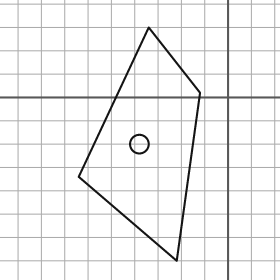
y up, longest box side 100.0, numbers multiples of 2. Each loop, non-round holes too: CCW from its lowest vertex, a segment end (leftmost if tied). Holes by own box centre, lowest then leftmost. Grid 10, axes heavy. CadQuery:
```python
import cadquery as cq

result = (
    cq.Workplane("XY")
    .moveTo(-22.0, -70.0)
    .lineTo(-12.0, 2.0)
    .lineTo(-34.0, 30.0)
    .lineTo(-64.0, -34.0)
    .close()
    .moveTo(-38.0, -20.0)
    .circle(4.0)
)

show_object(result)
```